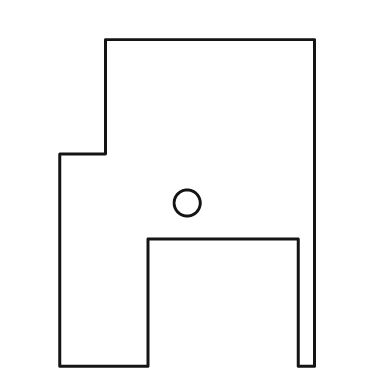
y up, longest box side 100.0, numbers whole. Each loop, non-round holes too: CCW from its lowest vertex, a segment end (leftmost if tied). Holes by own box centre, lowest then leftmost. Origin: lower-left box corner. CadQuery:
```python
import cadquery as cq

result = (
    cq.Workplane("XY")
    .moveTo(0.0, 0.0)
    .lineTo(27.0, 0.0)
    .lineTo(27.0, 39.0)
    .lineTo(73.0, 39.0)
    .lineTo(73.0, 0.0)
    .lineTo(78.0, 0.0)
    .lineTo(78.0, 100.0)
    .lineTo(14.0, 100.0)
    .lineTo(14.0, 65.0)
    .lineTo(0.0, 65.0)
    .close()
    .moveTo(39.0, 50.0)
    .circle(4.0)
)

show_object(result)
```